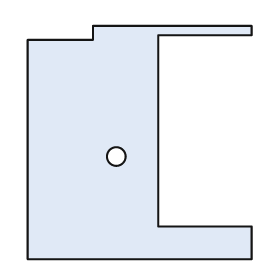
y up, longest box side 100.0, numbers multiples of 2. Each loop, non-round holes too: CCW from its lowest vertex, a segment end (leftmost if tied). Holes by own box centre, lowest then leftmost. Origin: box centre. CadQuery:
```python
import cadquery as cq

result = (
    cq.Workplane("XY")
    .moveTo(-48.0, -50.0)
    .lineTo(48.0, -50.0)
    .lineTo(48.0, -36.0)
    .lineTo(8.0, -36.0)
    .lineTo(8.0, 46.0)
    .lineTo(48.0, 46.0)
    .lineTo(48.0, 50.0)
    .lineTo(-20.0, 50.0)
    .lineTo(-20.0, 44.0)
    .lineTo(-48.0, 44.0)
    .close()
    .moveTo(-10.0, -6.0)
    .circle(4.0)
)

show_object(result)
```